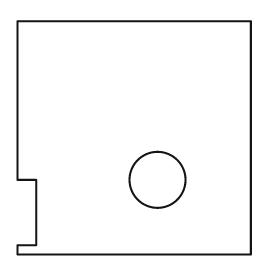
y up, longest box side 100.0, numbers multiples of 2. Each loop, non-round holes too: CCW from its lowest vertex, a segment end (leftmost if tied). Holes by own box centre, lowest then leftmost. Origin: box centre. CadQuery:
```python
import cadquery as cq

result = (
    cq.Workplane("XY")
    .moveTo(-50.0, -50.0)
    .lineTo(50.0, -50.0)
    .lineTo(50.0, 50.0)
    .lineTo(-50.0, 50.0)
    .lineTo(-50.0, -18.0)
    .lineTo(-42.0, -18.0)
    .lineTo(-42.0, -46.0)
    .lineTo(-50.0, -46.0)
    .close()
    .moveTo(10.0, -18.0)
    .circle(12.0)
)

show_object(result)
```